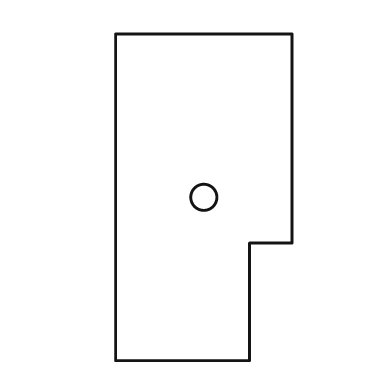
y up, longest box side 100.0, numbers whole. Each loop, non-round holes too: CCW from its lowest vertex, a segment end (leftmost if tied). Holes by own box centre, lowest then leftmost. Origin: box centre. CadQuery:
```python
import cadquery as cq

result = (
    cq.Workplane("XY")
    .moveTo(-27.0, -50.0)
    .lineTo(14.0, -50.0)
    .lineTo(14.0, -14.0)
    .lineTo(27.0, -14.0)
    .lineTo(27.0, 50.0)
    .lineTo(-27.0, 50.0)
    .close()
    .moveTo(0.0, 0.0)
    .circle(4.0)
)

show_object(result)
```